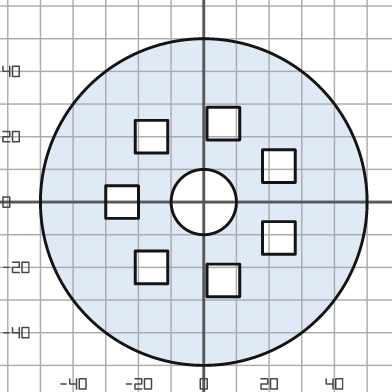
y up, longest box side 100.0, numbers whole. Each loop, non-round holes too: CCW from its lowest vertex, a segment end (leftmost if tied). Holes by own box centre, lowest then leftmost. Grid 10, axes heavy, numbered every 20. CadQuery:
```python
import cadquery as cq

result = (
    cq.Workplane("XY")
    .moveTo(0.0, 0.0)
    .circle(50.0)
    .moveTo(1.0, -29.0)
    .lineTo(11.0, -29.0)
    .lineTo(11.0, -19.0)
    .lineTo(1.0, -19.0)
    .close()
    .moveTo(-21.0, -25.0)
    .lineTo(-11.0, -25.0)
    .lineTo(-11.0, -15.0)
    .lineTo(-21.0, -15.0)
    .close()
    .moveTo(18.0, -16.0)
    .lineTo(28.0, -16.0)
    .lineTo(28.0, -6.0)
    .lineTo(18.0, -6.0)
    .close()
    .moveTo(-30.0, -5.0)
    .lineTo(-20.0, -5.0)
    .lineTo(-20.0, 5.0)
    .lineTo(-30.0, 5.0)
    .close()
    .moveTo(0.0, 0.0)
    .circle(10.0)
    .moveTo(18.0, 6.0)
    .lineTo(28.0, 6.0)
    .lineTo(28.0, 16.0)
    .lineTo(18.0, 16.0)
    .close()
    .moveTo(-21.0, 15.0)
    .lineTo(-11.0, 15.0)
    .lineTo(-11.0, 25.0)
    .lineTo(-21.0, 25.0)
    .close()
    .moveTo(1.0, 19.0)
    .lineTo(11.0, 19.0)
    .lineTo(11.0, 29.0)
    .lineTo(1.0, 29.0)
    .close()
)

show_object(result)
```